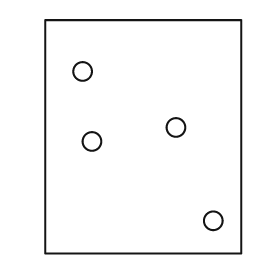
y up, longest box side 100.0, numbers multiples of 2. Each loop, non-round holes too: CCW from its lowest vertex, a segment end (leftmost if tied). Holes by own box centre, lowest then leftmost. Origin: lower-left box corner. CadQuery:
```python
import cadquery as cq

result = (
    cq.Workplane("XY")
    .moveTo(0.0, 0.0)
    .lineTo(84.0, 0.0)
    .lineTo(84.0, 100.0)
    .lineTo(0.0, 100.0)
    .close()
    .moveTo(72.0, 14.0)
    .circle(4.0)
    .moveTo(20.0, 48.0)
    .circle(4.0)
    .moveTo(56.0, 54.0)
    .circle(4.0)
    .moveTo(16.0, 78.0)
    .circle(4.0)
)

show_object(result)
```